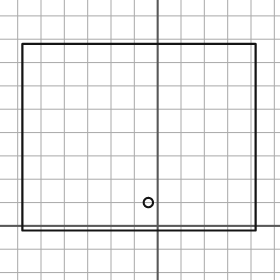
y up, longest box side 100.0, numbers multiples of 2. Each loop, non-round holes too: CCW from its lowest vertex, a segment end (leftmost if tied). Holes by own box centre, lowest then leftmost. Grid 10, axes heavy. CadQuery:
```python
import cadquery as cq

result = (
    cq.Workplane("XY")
    .moveTo(-58.0, -2.0)
    .lineTo(42.0, -2.0)
    .lineTo(42.0, 78.0)
    .lineTo(-58.0, 78.0)
    .close()
    .moveTo(-4.0, 10.0)
    .circle(2.0)
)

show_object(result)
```